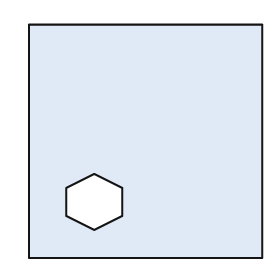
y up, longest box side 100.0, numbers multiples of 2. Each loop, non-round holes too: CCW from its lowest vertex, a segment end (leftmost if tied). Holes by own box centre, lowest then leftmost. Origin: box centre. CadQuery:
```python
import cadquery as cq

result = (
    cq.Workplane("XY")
    .moveTo(-50.0, -50.0)
    .lineTo(50.0, -50.0)
    .lineTo(50.0, 50.0)
    .lineTo(-50.0, 50.0)
    .close()
    .moveTo(-22.0, -38.0)
    .lineTo(-10.0, -32.0)
    .lineTo(-10.0, -20.0)
    .lineTo(-22.0, -14.0)
    .lineTo(-34.0, -20.0)
    .lineTo(-34.0, -32.0)
    .close()
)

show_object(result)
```